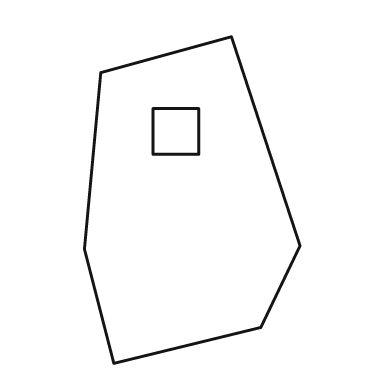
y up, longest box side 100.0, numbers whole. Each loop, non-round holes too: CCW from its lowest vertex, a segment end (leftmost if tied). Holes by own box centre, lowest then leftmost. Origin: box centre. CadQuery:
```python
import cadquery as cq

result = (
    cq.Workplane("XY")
    .moveTo(-24.0, -50.0)
    .lineTo(21.0, -39.0)
    .lineTo(33.0, -14.0)
    .lineTo(12.0, 50.0)
    .lineTo(-28.0, 39.0)
    .lineTo(-33.0, -15.0)
    .close()
    .moveTo(-12.0, 14.0)
    .lineTo(2.0, 14.0)
    .lineTo(2.0, 28.0)
    .lineTo(-12.0, 28.0)
    .close()
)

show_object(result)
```